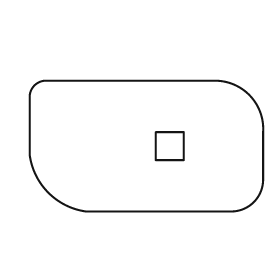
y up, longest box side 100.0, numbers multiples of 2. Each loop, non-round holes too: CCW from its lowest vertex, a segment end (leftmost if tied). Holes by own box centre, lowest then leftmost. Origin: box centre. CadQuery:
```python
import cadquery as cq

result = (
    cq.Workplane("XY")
    .moveTo(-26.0, -28.0)
    .lineTo(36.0, -28.0)
    .threePointArc((46.0, -24.0), (50.0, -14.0))
    .lineTo(50.0, 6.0)
    .threePointArc((44.0, 22.0), (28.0, 28.0))
    .lineTo(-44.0, 28.0)
    .threePointArc((-48.0, 26.0), (-50.0, 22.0))
    .lineTo(-50.0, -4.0)
    .threePointArc((-42.0, -20.0), (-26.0, -28.0))
    .close()
    .moveTo(4.0, -6.0)
    .lineTo(16.0, -6.0)
    .lineTo(16.0, 6.0)
    .lineTo(4.0, 6.0)
    .close()
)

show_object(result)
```